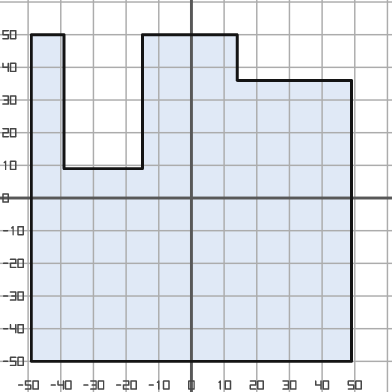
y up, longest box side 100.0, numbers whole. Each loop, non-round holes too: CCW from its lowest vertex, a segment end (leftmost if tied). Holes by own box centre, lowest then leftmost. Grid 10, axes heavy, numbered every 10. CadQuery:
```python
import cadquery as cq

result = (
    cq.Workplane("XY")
    .moveTo(-49.0, -50.0)
    .lineTo(49.0, -50.0)
    .lineTo(49.0, 36.0)
    .lineTo(14.0, 36.0)
    .lineTo(14.0, 50.0)
    .lineTo(-15.0, 50.0)
    .lineTo(-15.0, 9.0)
    .lineTo(-39.0, 9.0)
    .lineTo(-39.0, 50.0)
    .lineTo(-49.0, 50.0)
    .close()
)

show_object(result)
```